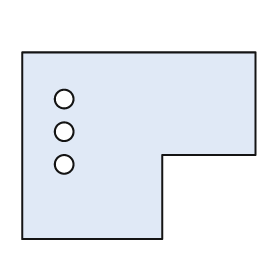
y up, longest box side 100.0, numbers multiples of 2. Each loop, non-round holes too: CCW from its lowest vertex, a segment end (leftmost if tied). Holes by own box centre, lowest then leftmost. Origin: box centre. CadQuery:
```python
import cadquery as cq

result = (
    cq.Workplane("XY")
    .moveTo(-50.0, -40.0)
    .lineTo(10.0, -40.0)
    .lineTo(10.0, -4.0)
    .lineTo(50.0, -4.0)
    .lineTo(50.0, 40.0)
    .lineTo(-50.0, 40.0)
    .close()
    .moveTo(-32.0, -8.0)
    .circle(4.0)
    .moveTo(-32.0, 6.0)
    .circle(4.0)
    .moveTo(-32.0, 20.0)
    .circle(4.0)
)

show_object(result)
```